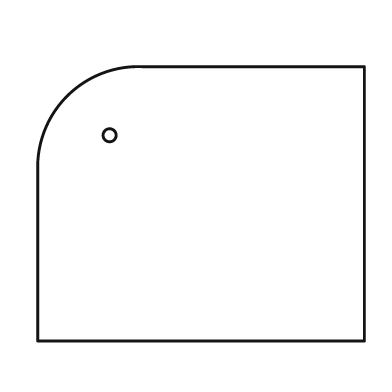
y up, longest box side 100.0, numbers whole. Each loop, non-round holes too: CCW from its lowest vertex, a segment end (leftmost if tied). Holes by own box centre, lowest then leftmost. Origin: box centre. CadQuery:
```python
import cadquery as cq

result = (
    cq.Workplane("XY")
    .moveTo(-50.0, -42.0)
    .lineTo(50.0, -42.0)
    .lineTo(50.0, 42.0)
    .lineTo(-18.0, 42.0)
    .threePointArc((-41.0, 33.0), (-50.0, 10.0))
    .close()
    .moveTo(-28.0, 21.0)
    .circle(2.0)
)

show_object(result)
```